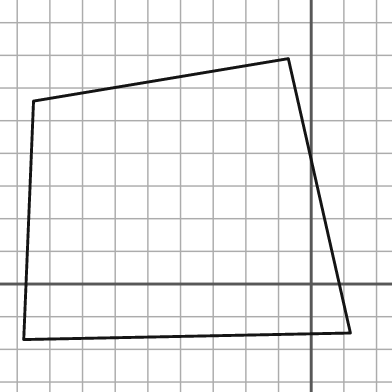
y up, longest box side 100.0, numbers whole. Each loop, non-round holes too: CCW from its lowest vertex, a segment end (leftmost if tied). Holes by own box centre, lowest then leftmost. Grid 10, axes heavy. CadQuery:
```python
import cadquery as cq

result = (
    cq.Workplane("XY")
    .moveTo(-88.0, -17.0)
    .lineTo(12.0, -15.0)
    .lineTo(-7.0, 69.0)
    .lineTo(-85.0, 56.0)
    .close()
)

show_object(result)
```